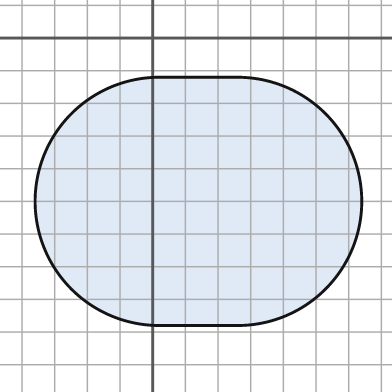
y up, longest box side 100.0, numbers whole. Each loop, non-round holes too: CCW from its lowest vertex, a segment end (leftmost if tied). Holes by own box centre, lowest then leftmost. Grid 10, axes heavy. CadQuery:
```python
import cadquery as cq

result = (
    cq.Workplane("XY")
    .moveTo(2.0, -88.0)
    .lineTo(26.0, -88.0)
    .threePointArc((64.0, -50.0), (26.0, -12.0))
    .lineTo(2.0, -12.0)
    .threePointArc((-36.0, -50.0), (2.0, -88.0))
    .close()
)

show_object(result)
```